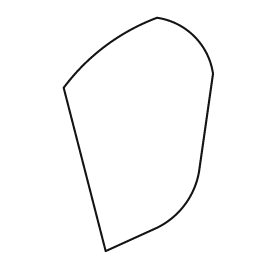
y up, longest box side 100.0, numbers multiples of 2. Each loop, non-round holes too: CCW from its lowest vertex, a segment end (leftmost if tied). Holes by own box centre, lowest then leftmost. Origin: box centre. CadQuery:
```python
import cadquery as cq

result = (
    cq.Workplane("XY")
    .moveTo(-14.0, -50.0)
    .lineTo(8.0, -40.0)
    .threePointArc((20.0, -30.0), (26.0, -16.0))
    .lineTo(32.0, 26.0)
    .threePointArc((24.0, 42.0), (8.0, 50.0))
    .threePointArc((-14.0, 38.0), (-32.0, 20.0))
    .close()
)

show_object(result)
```